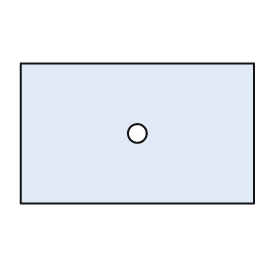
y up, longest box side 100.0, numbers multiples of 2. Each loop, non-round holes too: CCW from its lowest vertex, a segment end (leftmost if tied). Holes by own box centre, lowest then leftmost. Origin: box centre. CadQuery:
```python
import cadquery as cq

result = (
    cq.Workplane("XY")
    .moveTo(-50.0, -30.0)
    .lineTo(50.0, -30.0)
    .lineTo(50.0, 30.0)
    .lineTo(-50.0, 30.0)
    .close()
    .moveTo(0.0, 0.0)
    .circle(4.0)
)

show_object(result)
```